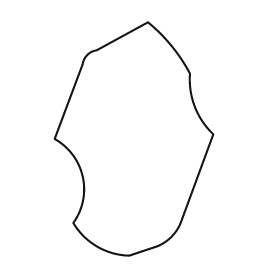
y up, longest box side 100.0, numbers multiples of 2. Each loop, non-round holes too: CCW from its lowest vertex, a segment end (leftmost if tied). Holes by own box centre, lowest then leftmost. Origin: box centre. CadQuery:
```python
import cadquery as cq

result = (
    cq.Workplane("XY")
    .moveTo(-2.0, -50.0)
    .lineTo(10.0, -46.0)
    .threePointArc((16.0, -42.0), (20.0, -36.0))
    .lineTo(34.0, 2.0)
    .threePointArc((26.0, 14.0), (24.0, 28.0))
    .threePointArc((16.0, 40.0), (6.0, 50.0))
    .lineTo(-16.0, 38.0)
    .threePointArc((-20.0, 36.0), (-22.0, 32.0))
    .lineTo(-34.0, 0.0)
    .threePointArc((-22.0, -16.0), (-26.0, -36.0))
    .threePointArc((-16.0, -46.0), (-2.0, -50.0))
    .close()
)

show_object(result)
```